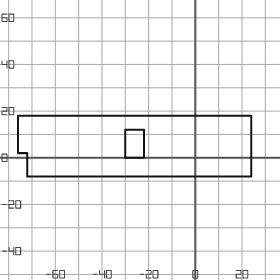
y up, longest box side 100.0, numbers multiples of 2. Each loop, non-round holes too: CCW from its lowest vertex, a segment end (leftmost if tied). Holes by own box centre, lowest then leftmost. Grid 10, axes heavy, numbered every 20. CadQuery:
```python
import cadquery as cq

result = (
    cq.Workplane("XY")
    .moveTo(-72.0, -8.0)
    .lineTo(24.0, -8.0)
    .lineTo(24.0, 18.0)
    .lineTo(-76.0, 18.0)
    .lineTo(-76.0, 2.0)
    .lineTo(-72.0, 2.0)
    .close()
    .moveTo(-30.0, 0.0)
    .lineTo(-22.0, 0.0)
    .lineTo(-22.0, 12.0)
    .lineTo(-30.0, 12.0)
    .close()
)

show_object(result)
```